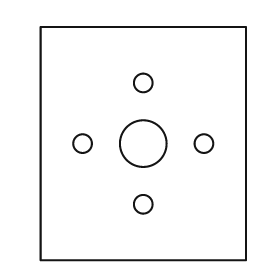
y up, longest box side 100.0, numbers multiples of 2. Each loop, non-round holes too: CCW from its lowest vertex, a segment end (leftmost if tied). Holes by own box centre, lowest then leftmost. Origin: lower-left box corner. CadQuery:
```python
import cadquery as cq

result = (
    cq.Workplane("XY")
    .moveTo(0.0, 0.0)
    .lineTo(88.0, 0.0)
    .lineTo(88.0, 100.0)
    .lineTo(0.0, 100.0)
    .close()
    .moveTo(44.0, 24.0)
    .circle(4.0)
    .moveTo(18.0, 50.0)
    .circle(4.0)
    .moveTo(44.0, 50.0)
    .circle(10.0)
    .moveTo(70.0, 50.0)
    .circle(4.0)
    .moveTo(44.0, 76.0)
    .circle(4.0)
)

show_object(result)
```